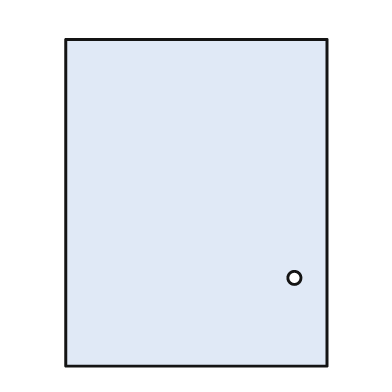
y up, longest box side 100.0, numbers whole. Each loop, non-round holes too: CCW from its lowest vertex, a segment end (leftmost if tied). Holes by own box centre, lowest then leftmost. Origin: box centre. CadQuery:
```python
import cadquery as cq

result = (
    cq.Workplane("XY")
    .moveTo(-40.0, -50.0)
    .lineTo(40.0, -50.0)
    .lineTo(40.0, 50.0)
    .lineTo(-40.0, 50.0)
    .close()
    .moveTo(30.0, -23.0)
    .circle(2.0)
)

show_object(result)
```